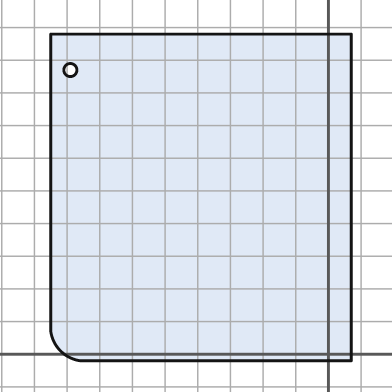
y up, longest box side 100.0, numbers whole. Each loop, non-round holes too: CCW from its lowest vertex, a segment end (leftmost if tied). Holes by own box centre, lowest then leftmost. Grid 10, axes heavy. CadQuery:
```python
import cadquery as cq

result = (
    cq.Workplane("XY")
    .moveTo(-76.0, -2.0)
    .lineTo(7.0, -2.0)
    .lineTo(7.0, 98.0)
    .lineTo(-85.0, 98.0)
    .lineTo(-85.0, 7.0)
    .threePointArc((-82.0, 1.0), (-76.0, -2.0))
    .close()
    .moveTo(-79.0, 87.0)
    .circle(2.0)
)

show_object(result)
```